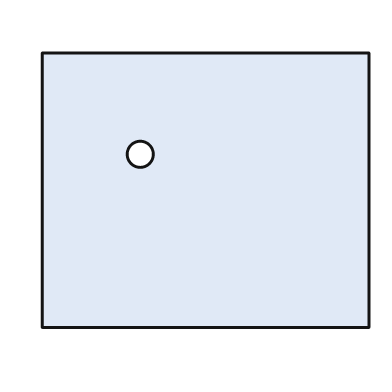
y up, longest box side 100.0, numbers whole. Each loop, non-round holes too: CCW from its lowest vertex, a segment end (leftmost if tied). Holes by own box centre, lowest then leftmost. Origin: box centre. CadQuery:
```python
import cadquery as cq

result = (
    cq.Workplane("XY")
    .moveTo(-50.0, -42.0)
    .lineTo(50.0, -42.0)
    .lineTo(50.0, 42.0)
    .lineTo(-50.0, 42.0)
    .close()
    .moveTo(-20.0, 11.0)
    .circle(4.0)
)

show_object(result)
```